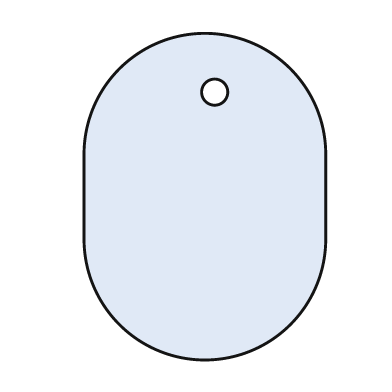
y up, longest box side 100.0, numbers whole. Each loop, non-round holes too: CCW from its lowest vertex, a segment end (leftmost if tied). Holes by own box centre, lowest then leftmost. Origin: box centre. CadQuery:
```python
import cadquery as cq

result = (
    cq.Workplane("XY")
    .moveTo(-37.0, -13.0)
    .threePointArc((0.0, -50.0), (37.0, -13.0))
    .lineTo(37.0, 13.0)
    .threePointArc((0.0, 50.0), (-37.0, 13.0))
    .close()
    .moveTo(3.0, 32.0)
    .circle(4.0)
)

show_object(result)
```